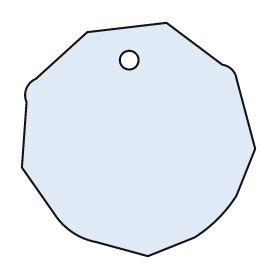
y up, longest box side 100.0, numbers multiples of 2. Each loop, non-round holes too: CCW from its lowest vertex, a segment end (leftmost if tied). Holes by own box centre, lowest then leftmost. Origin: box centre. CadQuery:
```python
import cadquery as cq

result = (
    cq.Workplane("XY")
    .moveTo(4.0, -50.0)
    .lineTo(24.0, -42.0)
    .threePointArc((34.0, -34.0), (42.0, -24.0))
    .lineTo(50.0, -4.0)
    .lineTo(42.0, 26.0)
    .threePointArc((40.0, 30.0), (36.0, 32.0))
    .lineTo(12.0, 50.0)
    .lineTo(-22.0, 46.0)
    .lineTo(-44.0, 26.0)
    .threePointArc((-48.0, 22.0), (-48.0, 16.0))
    .lineTo(-50.0, -12.0)
    .lineTo(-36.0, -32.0)
    .threePointArc((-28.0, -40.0), (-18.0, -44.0))
    .close()
    .moveTo(-4.0, 34.0)
    .circle(4.0)
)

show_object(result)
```